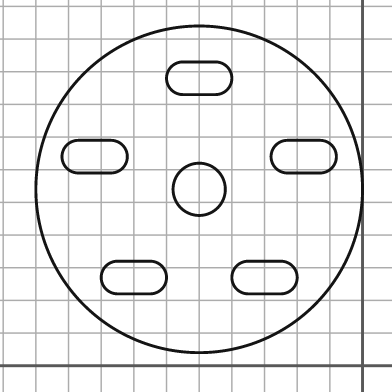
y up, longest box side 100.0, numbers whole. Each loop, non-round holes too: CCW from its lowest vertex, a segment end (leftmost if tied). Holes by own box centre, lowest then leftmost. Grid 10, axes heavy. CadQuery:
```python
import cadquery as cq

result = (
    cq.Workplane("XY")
    .moveTo(-50.0, 54.0)
    .circle(50.0)
    .moveTo(-75.0, 22.0)
    .lineTo(-65.0, 22.0)
    .threePointArc((-60.0, 27.0), (-65.0, 32.0))
    .lineTo(-75.0, 32.0)
    .threePointArc((-80.0, 27.0), (-75.0, 22.0))
    .close()
    .moveTo(-35.0, 22.0)
    .lineTo(-25.0, 22.0)
    .threePointArc((-20.0, 27.0), (-25.0, 32.0))
    .lineTo(-35.0, 32.0)
    .threePointArc((-40.0, 27.0), (-35.0, 22.0))
    .close()
    .moveTo(-50.0, 54.0)
    .circle(8.0)
    .moveTo(-87.0, 59.0)
    .lineTo(-77.0, 59.0)
    .threePointArc((-72.0, 64.0), (-77.0, 69.0))
    .lineTo(-87.0, 69.0)
    .threePointArc((-92.0, 64.0), (-87.0, 59.0))
    .close()
    .moveTo(-23.0, 59.0)
    .lineTo(-13.0, 59.0)
    .threePointArc((-8.0, 64.0), (-13.0, 69.0))
    .lineTo(-23.0, 69.0)
    .threePointArc((-28.0, 64.0), (-23.0, 59.0))
    .close()
    .moveTo(-55.0, 83.0)
    .lineTo(-45.0, 83.0)
    .threePointArc((-40.0, 88.0), (-45.0, 93.0))
    .lineTo(-55.0, 93.0)
    .threePointArc((-60.0, 88.0), (-55.0, 83.0))
    .close()
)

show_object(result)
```